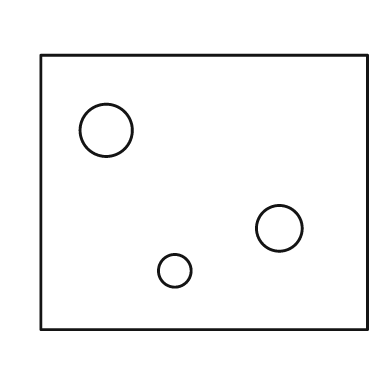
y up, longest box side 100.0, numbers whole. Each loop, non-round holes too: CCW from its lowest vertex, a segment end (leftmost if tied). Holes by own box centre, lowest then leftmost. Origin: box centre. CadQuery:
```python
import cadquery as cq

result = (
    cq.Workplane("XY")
    .moveTo(-50.0, -42.0)
    .lineTo(50.0, -42.0)
    .lineTo(50.0, 42.0)
    .lineTo(-50.0, 42.0)
    .close()
    .moveTo(-9.0, -24.0)
    .circle(5.0)
    .moveTo(23.0, -11.0)
    .circle(7.0)
    .moveTo(-30.0, 19.0)
    .circle(8.0)
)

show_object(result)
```